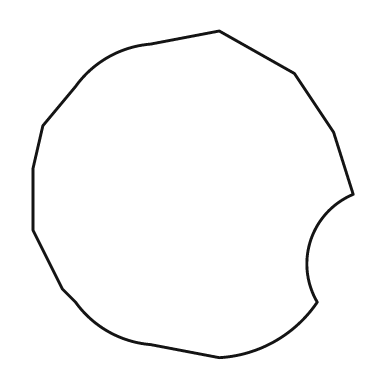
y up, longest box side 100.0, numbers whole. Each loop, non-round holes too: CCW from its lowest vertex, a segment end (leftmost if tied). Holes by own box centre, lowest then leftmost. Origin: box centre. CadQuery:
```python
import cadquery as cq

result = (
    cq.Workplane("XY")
    .moveTo(8.0, -50.0)
    .threePointArc((25.0, -45.0), (38.0, -33.0))
    .threePointArc((36.0, -14.0), (49.0, 0.0))
    .lineTo(43.0, 19.0)
    .lineTo(31.0, 37.0)
    .lineTo(8.0, 50.0)
    .lineTo(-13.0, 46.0)
    .threePointArc((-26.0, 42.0), (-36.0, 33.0))
    .lineTo(-46.0, 21.0)
    .lineTo(-49.0, 8.0)
    .lineTo(-49.0, -11.0)
    .lineTo(-40.0, -29.0)
    .lineTo(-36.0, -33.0)
    .threePointArc((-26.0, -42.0), (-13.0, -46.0))
    .close()
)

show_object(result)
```